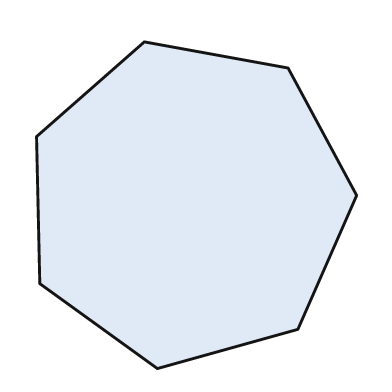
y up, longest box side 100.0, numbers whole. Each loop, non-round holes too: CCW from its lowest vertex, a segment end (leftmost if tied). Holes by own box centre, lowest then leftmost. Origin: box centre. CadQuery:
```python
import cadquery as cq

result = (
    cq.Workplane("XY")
    .moveTo(-12.0, -50.0)
    .lineTo(31.0, -38.0)
    .lineTo(49.0, 3.0)
    .lineTo(28.0, 42.0)
    .lineTo(-16.0, 50.0)
    .lineTo(-49.0, 21.0)
    .lineTo(-48.0, -24.0)
    .close()
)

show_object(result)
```